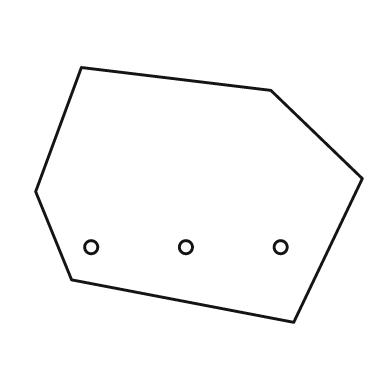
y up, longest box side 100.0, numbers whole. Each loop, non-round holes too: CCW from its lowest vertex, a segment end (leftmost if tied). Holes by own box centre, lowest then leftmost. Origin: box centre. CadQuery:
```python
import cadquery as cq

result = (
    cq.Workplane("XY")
    .moveTo(29.0, -39.0)
    .lineTo(50.0, 5.0)
    .lineTo(22.0, 32.0)
    .lineTo(-36.0, 39.0)
    .lineTo(-50.0, 1.0)
    .lineTo(-39.0, -26.0)
    .close()
    .moveTo(-33.0, -16.0)
    .circle(2.0)
    .moveTo(-4.0, -16.0)
    .circle(2.0)
    .moveTo(25.0, -16.0)
    .circle(2.0)
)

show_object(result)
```